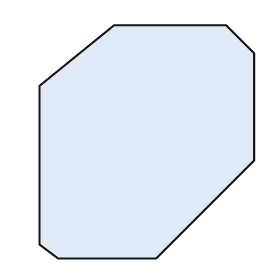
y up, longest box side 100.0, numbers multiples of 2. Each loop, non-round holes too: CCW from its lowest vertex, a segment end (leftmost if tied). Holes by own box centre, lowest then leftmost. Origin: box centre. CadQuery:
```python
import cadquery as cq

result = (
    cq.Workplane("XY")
    .moveTo(-38.0, -50.0)
    .lineTo(4.0, -50.0)
    .lineTo(46.0, -8.0)
    .lineTo(46.0, 38.0)
    .lineTo(34.0, 50.0)
    .lineTo(-14.0, 50.0)
    .lineTo(-46.0, 24.0)
    .lineTo(-46.0, -44.0)
    .close()
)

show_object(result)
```